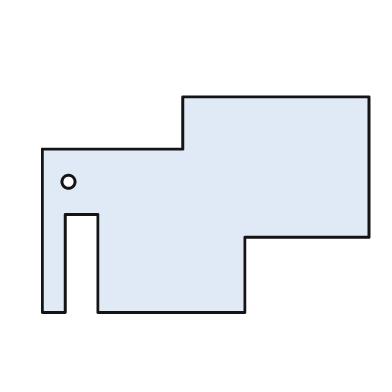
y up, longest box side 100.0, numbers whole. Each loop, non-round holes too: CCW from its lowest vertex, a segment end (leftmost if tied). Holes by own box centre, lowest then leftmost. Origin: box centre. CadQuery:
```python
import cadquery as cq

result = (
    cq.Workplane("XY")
    .moveTo(-50.0, -33.0)
    .lineTo(-43.0, -33.0)
    .lineTo(-43.0, -3.0)
    .lineTo(-33.0, -3.0)
    .lineTo(-33.0, -33.0)
    .lineTo(12.0, -33.0)
    .lineTo(12.0, -10.0)
    .lineTo(50.0, -10.0)
    .lineTo(50.0, 33.0)
    .lineTo(-7.0, 33.0)
    .lineTo(-7.0, 17.0)
    .lineTo(-50.0, 17.0)
    .close()
    .moveTo(-42.0, 7.0)
    .circle(2.0)
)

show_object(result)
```